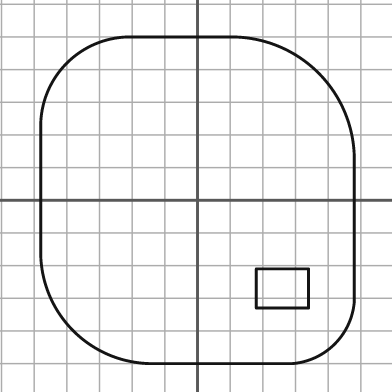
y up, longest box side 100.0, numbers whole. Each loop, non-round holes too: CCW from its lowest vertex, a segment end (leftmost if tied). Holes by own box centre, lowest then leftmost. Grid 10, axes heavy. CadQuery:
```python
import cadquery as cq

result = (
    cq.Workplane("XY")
    .moveTo(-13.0, -50.0)
    .lineTo(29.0, -50.0)
    .threePointArc((42.0, -44.0), (48.0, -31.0))
    .lineTo(48.0, 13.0)
    .threePointArc((37.0, 39.0), (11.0, 50.0))
    .lineTo(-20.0, 50.0)
    .threePointArc((-40.0, 42.0), (-48.0, 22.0))
    .lineTo(-48.0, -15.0)
    .threePointArc((-38.0, -40.0), (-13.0, -50.0))
    .close()
    .moveTo(18.0, -33.0)
    .lineTo(34.0, -33.0)
    .lineTo(34.0, -21.0)
    .lineTo(18.0, -21.0)
    .close()
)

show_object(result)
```